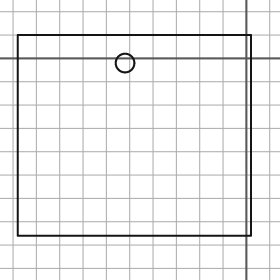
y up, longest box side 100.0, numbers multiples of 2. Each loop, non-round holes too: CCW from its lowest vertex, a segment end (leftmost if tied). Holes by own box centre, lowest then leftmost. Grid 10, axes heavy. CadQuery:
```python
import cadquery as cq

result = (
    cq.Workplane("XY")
    .moveTo(-98.0, -76.0)
    .lineTo(2.0, -76.0)
    .lineTo(2.0, 10.0)
    .lineTo(-98.0, 10.0)
    .close()
    .moveTo(-52.0, -2.0)
    .circle(4.0)
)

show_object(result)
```